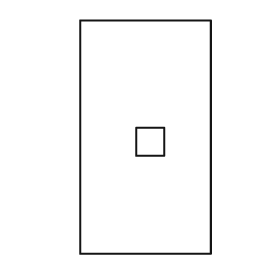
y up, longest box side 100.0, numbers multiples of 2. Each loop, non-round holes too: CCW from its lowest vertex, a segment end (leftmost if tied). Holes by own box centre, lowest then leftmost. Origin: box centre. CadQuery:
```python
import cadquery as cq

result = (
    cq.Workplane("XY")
    .moveTo(-28.0, -50.0)
    .lineTo(28.0, -50.0)
    .lineTo(28.0, 50.0)
    .lineTo(-28.0, 50.0)
    .close()
    .moveTo(-4.0, -8.0)
    .lineTo(8.0, -8.0)
    .lineTo(8.0, 4.0)
    .lineTo(-4.0, 4.0)
    .close()
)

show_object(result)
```